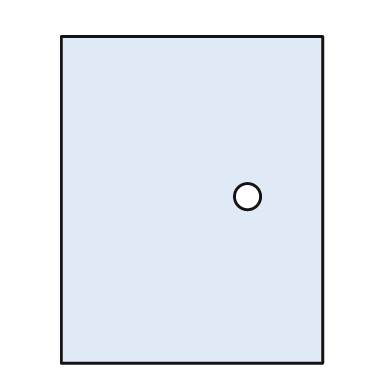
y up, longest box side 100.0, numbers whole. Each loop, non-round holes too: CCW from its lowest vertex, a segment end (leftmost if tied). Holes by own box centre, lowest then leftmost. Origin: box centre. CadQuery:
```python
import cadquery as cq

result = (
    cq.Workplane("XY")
    .moveTo(-40.0, -50.0)
    .lineTo(40.0, -50.0)
    .lineTo(40.0, 50.0)
    .lineTo(-40.0, 50.0)
    .close()
    .moveTo(17.0, 1.0)
    .circle(4.0)
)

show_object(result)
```